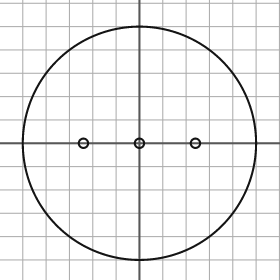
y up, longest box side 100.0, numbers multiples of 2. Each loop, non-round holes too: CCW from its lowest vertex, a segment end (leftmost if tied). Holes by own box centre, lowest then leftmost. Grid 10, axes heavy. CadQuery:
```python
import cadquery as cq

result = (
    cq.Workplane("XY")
    .moveTo(0.0, 0.0)
    .circle(50.0)
    .moveTo(-24.0, 0.0)
    .circle(2.0)
    .moveTo(0.0, 0.0)
    .circle(2.0)
    .moveTo(24.0, 0.0)
    .circle(2.0)
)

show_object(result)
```